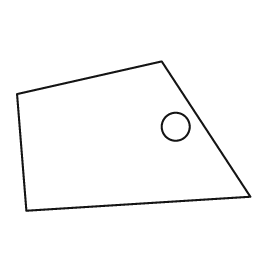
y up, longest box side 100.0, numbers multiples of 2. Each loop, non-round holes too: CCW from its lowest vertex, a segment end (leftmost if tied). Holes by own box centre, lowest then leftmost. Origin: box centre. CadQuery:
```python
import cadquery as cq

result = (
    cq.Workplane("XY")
    .moveTo(-46.0, -32.0)
    .lineTo(50.0, -26.0)
    .lineTo(12.0, 32.0)
    .lineTo(-50.0, 18.0)
    .close()
    .moveTo(18.0, 4.0)
    .circle(6.0)
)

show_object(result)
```